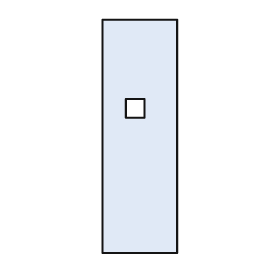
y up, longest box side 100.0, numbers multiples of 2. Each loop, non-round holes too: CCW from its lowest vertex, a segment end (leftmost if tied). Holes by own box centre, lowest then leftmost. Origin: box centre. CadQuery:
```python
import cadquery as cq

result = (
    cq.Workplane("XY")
    .moveTo(-16.0, -50.0)
    .lineTo(16.0, -50.0)
    .lineTo(16.0, 50.0)
    .lineTo(-16.0, 50.0)
    .close()
    .moveTo(-6.0, 8.0)
    .lineTo(2.0, 8.0)
    .lineTo(2.0, 16.0)
    .lineTo(-6.0, 16.0)
    .close()
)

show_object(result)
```